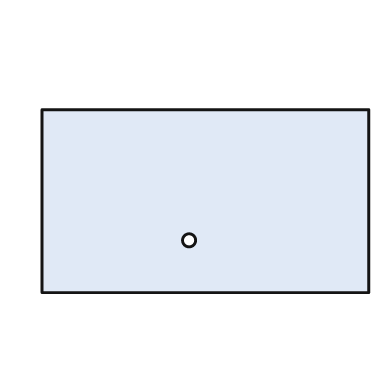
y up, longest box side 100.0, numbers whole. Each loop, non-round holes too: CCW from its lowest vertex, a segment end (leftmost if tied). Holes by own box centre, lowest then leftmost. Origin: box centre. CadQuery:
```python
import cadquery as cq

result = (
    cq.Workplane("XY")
    .moveTo(-50.0, -28.0)
    .lineTo(50.0, -28.0)
    .lineTo(50.0, 28.0)
    .lineTo(-50.0, 28.0)
    .close()
    .moveTo(-5.0, -12.0)
    .circle(2.0)
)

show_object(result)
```